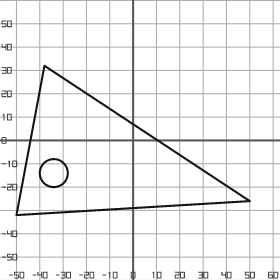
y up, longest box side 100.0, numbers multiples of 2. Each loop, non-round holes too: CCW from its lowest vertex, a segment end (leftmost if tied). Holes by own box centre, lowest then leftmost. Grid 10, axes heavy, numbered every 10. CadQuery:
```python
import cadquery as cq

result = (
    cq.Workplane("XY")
    .moveTo(-50.0, -32.0)
    .lineTo(50.0, -26.0)
    .lineTo(-38.0, 32.0)
    .close()
    .moveTo(-34.0, -14.0)
    .circle(6.0)
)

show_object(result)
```